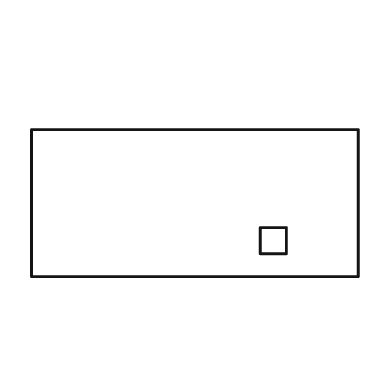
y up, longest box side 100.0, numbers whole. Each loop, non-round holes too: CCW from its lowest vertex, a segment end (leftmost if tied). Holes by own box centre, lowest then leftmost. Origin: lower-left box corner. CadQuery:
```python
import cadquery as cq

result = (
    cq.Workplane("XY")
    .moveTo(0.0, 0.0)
    .lineTo(100.0, 0.0)
    .lineTo(100.0, 45.0)
    .lineTo(0.0, 45.0)
    .close()
    .moveTo(70.0, 7.0)
    .lineTo(78.0, 7.0)
    .lineTo(78.0, 15.0)
    .lineTo(70.0, 15.0)
    .close()
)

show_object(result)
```